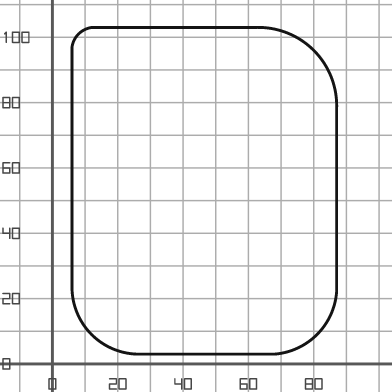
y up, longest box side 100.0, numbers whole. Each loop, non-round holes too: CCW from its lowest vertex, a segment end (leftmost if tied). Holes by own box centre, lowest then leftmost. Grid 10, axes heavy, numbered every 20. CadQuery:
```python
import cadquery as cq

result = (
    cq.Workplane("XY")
    .moveTo(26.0, 3.0)
    .lineTo(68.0, 3.0)
    .threePointArc((81.0, 9.0), (87.0, 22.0))
    .lineTo(87.0, 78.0)
    .threePointArc((80.0, 96.0), (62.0, 103.0))
    .lineTo(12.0, 103.0)
    .threePointArc((8.0, 101.0), (6.0, 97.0))
    .lineTo(6.0, 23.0)
    .threePointArc((12.0, 9.0), (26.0, 3.0))
    .close()
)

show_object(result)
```